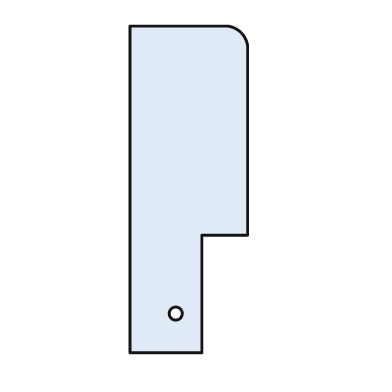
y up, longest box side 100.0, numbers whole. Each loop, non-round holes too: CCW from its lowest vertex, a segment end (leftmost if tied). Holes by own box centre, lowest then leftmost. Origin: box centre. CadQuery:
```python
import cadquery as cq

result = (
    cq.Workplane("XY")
    .moveTo(-18.0, -50.0)
    .lineTo(4.0, -50.0)
    .lineTo(4.0, -14.0)
    .lineTo(18.0, -14.0)
    .lineTo(18.0, 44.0)
    .threePointArc((16.0, 48.0), (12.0, 50.0))
    .lineTo(-18.0, 50.0)
    .close()
    .moveTo(-4.0, -38.0)
    .circle(2.0)
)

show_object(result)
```